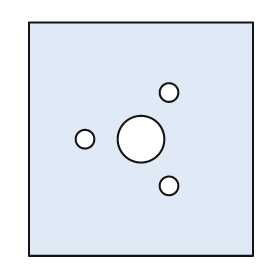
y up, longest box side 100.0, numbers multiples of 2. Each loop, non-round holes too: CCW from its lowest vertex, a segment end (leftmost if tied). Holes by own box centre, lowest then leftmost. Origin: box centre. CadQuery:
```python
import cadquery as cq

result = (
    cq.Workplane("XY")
    .moveTo(-48.0, -50.0)
    .lineTo(48.0, -50.0)
    .lineTo(48.0, 50.0)
    .lineTo(-48.0, 50.0)
    .close()
    .moveTo(12.0, -20.0)
    .circle(4.0)
    .moveTo(-24.0, 0.0)
    .circle(4.0)
    .moveTo(0.0, 0.0)
    .circle(10.0)
    .moveTo(12.0, 20.0)
    .circle(4.0)
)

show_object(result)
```